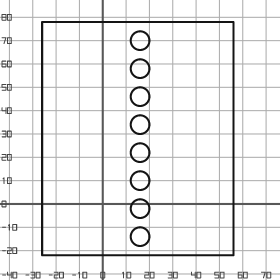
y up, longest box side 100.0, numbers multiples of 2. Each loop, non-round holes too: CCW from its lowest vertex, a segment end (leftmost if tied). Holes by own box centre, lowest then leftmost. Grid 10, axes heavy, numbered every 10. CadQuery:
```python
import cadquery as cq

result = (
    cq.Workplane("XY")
    .moveTo(-26.0, -22.0)
    .lineTo(56.0, -22.0)
    .lineTo(56.0, 78.0)
    .lineTo(-26.0, 78.0)
    .close()
    .moveTo(16.0, -14.0)
    .circle(4.0)
    .moveTo(16.0, -2.0)
    .circle(4.0)
    .moveTo(16.0, 10.0)
    .circle(4.0)
    .moveTo(16.0, 22.0)
    .circle(4.0)
    .moveTo(16.0, 34.0)
    .circle(4.0)
    .moveTo(16.0, 46.0)
    .circle(4.0)
    .moveTo(16.0, 58.0)
    .circle(4.0)
    .moveTo(16.0, 70.0)
    .circle(4.0)
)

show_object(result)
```